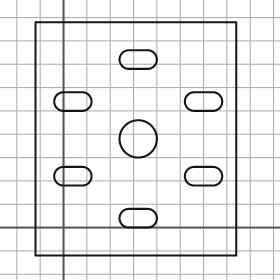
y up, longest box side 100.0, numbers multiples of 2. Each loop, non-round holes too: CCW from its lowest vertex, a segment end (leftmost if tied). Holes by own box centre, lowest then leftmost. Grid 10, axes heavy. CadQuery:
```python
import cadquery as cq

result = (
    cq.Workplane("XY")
    .moveTo(-12.0, -12.0)
    .lineTo(74.0, -12.0)
    .lineTo(74.0, 88.0)
    .lineTo(-12.0, 88.0)
    .close()
    .moveTo(28.0, 0.0)
    .lineTo(36.0, 0.0)
    .threePointArc((40.0, 4.0), (36.0, 8.0))
    .lineTo(28.0, 8.0)
    .threePointArc((24.0, 4.0), (28.0, 0.0))
    .close()
    .moveTo(0.0, 18.0)
    .lineTo(8.0, 18.0)
    .threePointArc((12.0, 22.0), (8.0, 26.0))
    .lineTo(0.0, 26.0)
    .threePointArc((-4.0, 22.0), (0.0, 18.0))
    .close()
    .moveTo(56.0, 18.0)
    .lineTo(64.0, 18.0)
    .threePointArc((68.0, 22.0), (64.0, 26.0))
    .lineTo(56.0, 26.0)
    .threePointArc((52.0, 22.0), (56.0, 18.0))
    .close()
    .moveTo(32.0, 38.0)
    .circle(8.0)
    .moveTo(0.0, 50.0)
    .lineTo(8.0, 50.0)
    .threePointArc((12.0, 54.0), (8.0, 58.0))
    .lineTo(0.0, 58.0)
    .threePointArc((-4.0, 54.0), (0.0, 50.0))
    .close()
    .moveTo(56.0, 50.0)
    .lineTo(64.0, 50.0)
    .threePointArc((68.0, 54.0), (64.0, 58.0))
    .lineTo(56.0, 58.0)
    .threePointArc((52.0, 54.0), (56.0, 50.0))
    .close()
    .moveTo(28.0, 68.0)
    .lineTo(36.0, 68.0)
    .threePointArc((40.0, 72.0), (36.0, 76.0))
    .lineTo(28.0, 76.0)
    .threePointArc((24.0, 72.0), (28.0, 68.0))
    .close()
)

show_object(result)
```